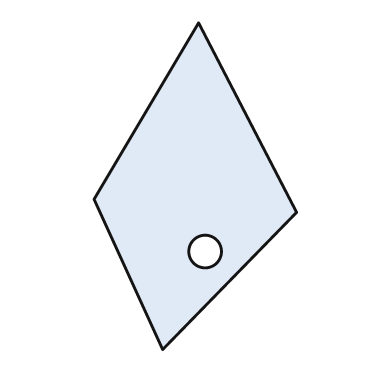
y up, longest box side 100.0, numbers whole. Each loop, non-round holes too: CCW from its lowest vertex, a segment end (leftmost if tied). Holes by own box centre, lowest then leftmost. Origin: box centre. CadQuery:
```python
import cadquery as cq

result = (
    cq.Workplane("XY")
    .moveTo(-10.0, -50.0)
    .lineTo(31.0, -8.0)
    .lineTo(1.0, 50.0)
    .lineTo(-31.0, -4.0)
    .close()
    .moveTo(3.0, -20.0)
    .circle(5.0)
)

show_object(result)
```